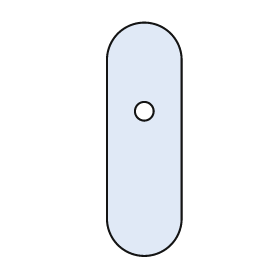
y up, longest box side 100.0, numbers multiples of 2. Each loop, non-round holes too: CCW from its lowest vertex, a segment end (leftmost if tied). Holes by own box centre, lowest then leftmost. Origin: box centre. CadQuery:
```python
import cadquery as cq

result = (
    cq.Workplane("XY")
    .moveTo(-16.0, -34.0)
    .threePointArc((0.0, -50.0), (16.0, -34.0))
    .lineTo(16.0, 34.0)
    .threePointArc((0.0, 50.0), (-16.0, 34.0))
    .close()
    .moveTo(0.0, 12.0)
    .circle(4.0)
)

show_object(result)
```